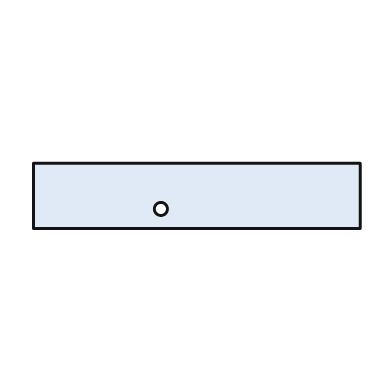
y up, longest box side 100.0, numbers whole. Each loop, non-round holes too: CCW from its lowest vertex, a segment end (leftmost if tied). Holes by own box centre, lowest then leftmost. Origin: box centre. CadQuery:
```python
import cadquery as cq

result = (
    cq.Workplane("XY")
    .moveTo(-50.0, -10.0)
    .lineTo(50.0, -10.0)
    .lineTo(50.0, 10.0)
    .lineTo(-50.0, 10.0)
    .close()
    .moveTo(-11.0, -4.0)
    .circle(2.0)
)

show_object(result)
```